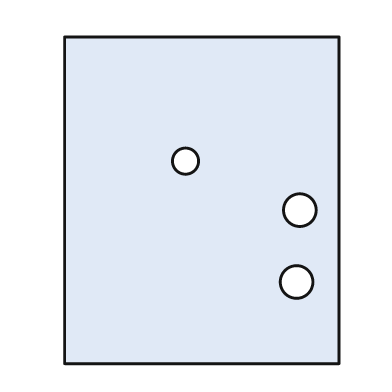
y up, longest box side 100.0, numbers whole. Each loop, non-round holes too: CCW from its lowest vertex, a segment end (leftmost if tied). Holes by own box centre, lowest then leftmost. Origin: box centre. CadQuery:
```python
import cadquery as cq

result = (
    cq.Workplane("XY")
    .moveTo(-42.0, -50.0)
    .lineTo(42.0, -50.0)
    .lineTo(42.0, 50.0)
    .lineTo(-42.0, 50.0)
    .close()
    .moveTo(29.0, -25.0)
    .circle(5.0)
    .moveTo(30.0, -3.0)
    .circle(5.0)
    .moveTo(-5.0, 12.0)
    .circle(4.0)
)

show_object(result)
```